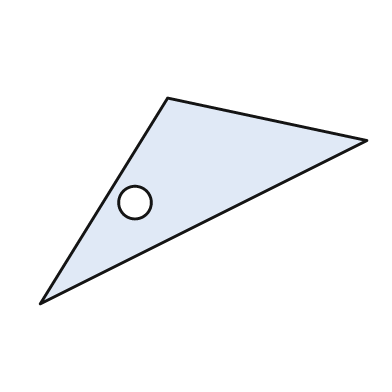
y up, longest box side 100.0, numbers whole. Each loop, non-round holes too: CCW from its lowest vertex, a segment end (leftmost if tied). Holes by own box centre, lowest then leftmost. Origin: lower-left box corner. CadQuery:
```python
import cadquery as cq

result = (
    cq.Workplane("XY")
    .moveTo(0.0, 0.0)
    .lineTo(100.0, 50.0)
    .lineTo(39.0, 63.0)
    .close()
    .moveTo(29.0, 31.0)
    .circle(5.0)
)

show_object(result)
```